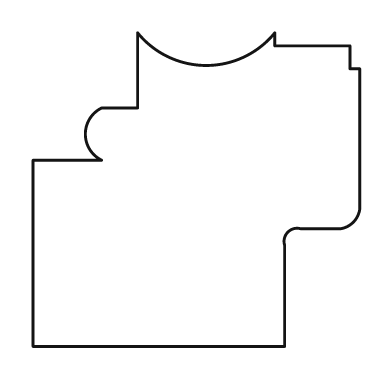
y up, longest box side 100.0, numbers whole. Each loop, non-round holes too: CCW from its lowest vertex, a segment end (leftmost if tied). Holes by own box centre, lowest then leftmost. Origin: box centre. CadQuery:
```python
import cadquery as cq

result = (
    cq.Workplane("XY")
    .moveTo(-50.0, -48.0)
    .lineTo(27.0, -48.0)
    .lineTo(27.0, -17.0)
    .threePointArc((28.0, -13.0), (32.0, -12.0))
    .lineTo(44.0, -12.0)
    .threePointArc((48.0, -10.0), (50.0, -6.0))
    .lineTo(50.0, 37.0)
    .lineTo(47.0, 37.0)
    .lineTo(47.0, 44.0)
    .lineTo(24.0, 44.0)
    .lineTo(24.0, 48.0)
    .threePointArc((3.0, 38.0), (-18.0, 48.0))
    .lineTo(-18.0, 25.0)
    .lineTo(-29.0, 25.0)
    .threePointArc((-34.0, 17.0), (-29.0, 9.0))
    .lineTo(-50.0, 9.0)
    .close()
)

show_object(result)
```